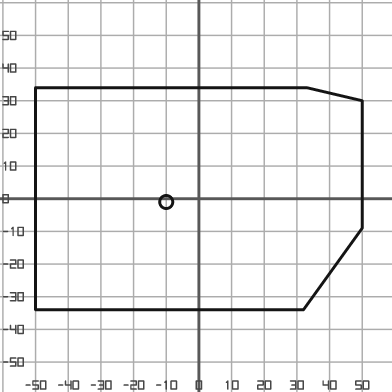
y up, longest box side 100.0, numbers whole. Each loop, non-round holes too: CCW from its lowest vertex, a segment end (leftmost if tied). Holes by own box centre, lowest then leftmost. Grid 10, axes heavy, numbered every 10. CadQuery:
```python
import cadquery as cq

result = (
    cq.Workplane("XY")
    .moveTo(-50.0, -34.0)
    .lineTo(32.0, -34.0)
    .lineTo(50.0, -9.0)
    .lineTo(50.0, 30.0)
    .lineTo(33.0, 34.0)
    .lineTo(-50.0, 34.0)
    .close()
    .moveTo(-10.0, -1.0)
    .circle(2.0)
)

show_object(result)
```